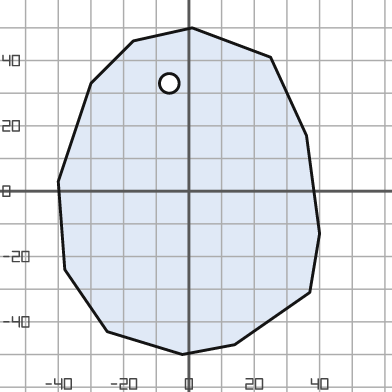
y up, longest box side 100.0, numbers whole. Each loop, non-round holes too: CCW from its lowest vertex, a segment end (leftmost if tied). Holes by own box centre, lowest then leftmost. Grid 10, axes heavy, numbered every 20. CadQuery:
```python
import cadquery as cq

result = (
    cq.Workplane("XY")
    .moveTo(-2.0, -50.0)
    .lineTo(14.0, -47.0)
    .lineTo(37.0, -31.0)
    .lineTo(40.0, -13.0)
    .lineTo(36.0, 17.0)
    .lineTo(25.0, 41.0)
    .lineTo(1.0, 50.0)
    .lineTo(-17.0, 46.0)
    .lineTo(-30.0, 33.0)
    .lineTo(-40.0, 3.0)
    .lineTo(-38.0, -24.0)
    .lineTo(-25.0, -43.0)
    .close()
    .moveTo(-6.0, 33.0)
    .circle(3.0)
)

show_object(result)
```